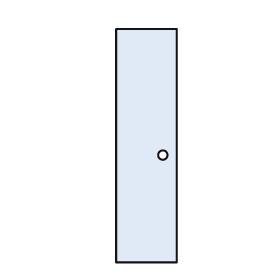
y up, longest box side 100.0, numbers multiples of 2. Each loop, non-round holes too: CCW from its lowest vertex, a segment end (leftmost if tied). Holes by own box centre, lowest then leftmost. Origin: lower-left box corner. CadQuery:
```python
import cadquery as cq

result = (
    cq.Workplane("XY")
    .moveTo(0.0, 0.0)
    .lineTo(26.0, 0.0)
    .lineTo(26.0, 100.0)
    .lineTo(0.0, 100.0)
    .close()
    .moveTo(20.0, 46.0)
    .circle(2.0)
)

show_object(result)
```